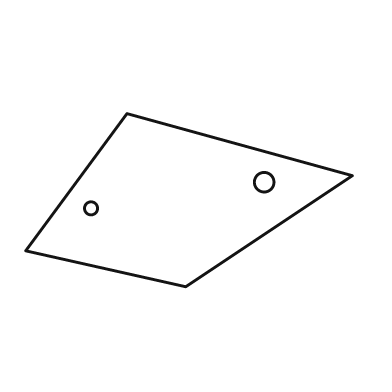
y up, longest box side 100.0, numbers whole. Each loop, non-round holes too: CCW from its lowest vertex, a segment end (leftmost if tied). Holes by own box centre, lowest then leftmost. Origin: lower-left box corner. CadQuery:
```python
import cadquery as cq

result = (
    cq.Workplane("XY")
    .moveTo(49.0, 0.0)
    .lineTo(100.0, 34.0)
    .lineTo(31.0, 53.0)
    .lineTo(0.0, 11.0)
    .close()
    .moveTo(20.0, 24.0)
    .circle(2.0)
    .moveTo(73.0, 32.0)
    .circle(3.0)
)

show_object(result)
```